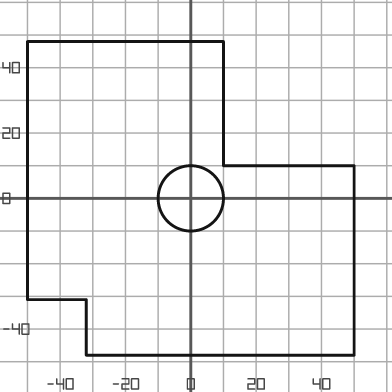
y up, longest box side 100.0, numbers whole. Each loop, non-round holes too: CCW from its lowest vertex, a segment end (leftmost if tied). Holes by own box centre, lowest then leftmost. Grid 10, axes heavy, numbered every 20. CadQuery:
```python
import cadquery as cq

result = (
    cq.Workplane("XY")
    .moveTo(-32.0, -48.0)
    .lineTo(50.0, -48.0)
    .lineTo(50.0, 10.0)
    .lineTo(10.0, 10.0)
    .lineTo(10.0, 48.0)
    .lineTo(-50.0, 48.0)
    .lineTo(-50.0, -31.0)
    .lineTo(-32.0, -31.0)
    .close()
    .moveTo(0.0, 0.0)
    .circle(10.0)
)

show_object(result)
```